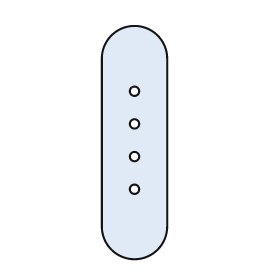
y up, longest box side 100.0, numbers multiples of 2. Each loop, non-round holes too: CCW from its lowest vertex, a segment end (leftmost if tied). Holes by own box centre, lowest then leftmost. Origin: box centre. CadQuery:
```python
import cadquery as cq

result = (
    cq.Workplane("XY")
    .moveTo(-14.0, -36.0)
    .threePointArc((0.0, -50.0), (14.0, -36.0))
    .lineTo(14.0, 36.0)
    .threePointArc((0.0, 50.0), (-14.0, 36.0))
    .close()
    .moveTo(0.0, -20.0)
    .circle(2.0)
    .moveTo(0.0, -6.0)
    .circle(2.0)
    .moveTo(0.0, 8.0)
    .circle(2.0)
    .moveTo(0.0, 22.0)
    .circle(2.0)
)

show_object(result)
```